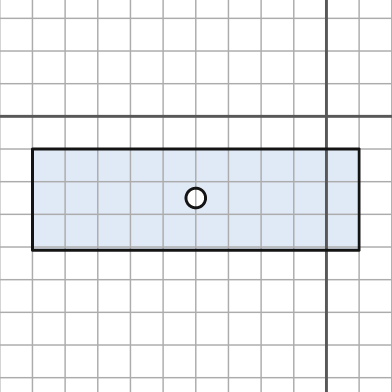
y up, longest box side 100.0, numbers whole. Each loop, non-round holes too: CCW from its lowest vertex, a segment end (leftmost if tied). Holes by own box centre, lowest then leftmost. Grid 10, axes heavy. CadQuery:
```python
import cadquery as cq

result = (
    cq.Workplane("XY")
    .moveTo(-90.0, -41.0)
    .lineTo(10.0, -41.0)
    .lineTo(10.0, -10.0)
    .lineTo(-90.0, -10.0)
    .close()
    .moveTo(-40.0, -25.0)
    .circle(3.0)
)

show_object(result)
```